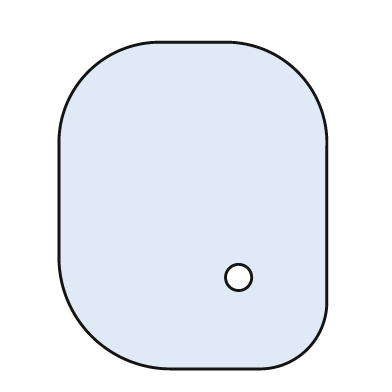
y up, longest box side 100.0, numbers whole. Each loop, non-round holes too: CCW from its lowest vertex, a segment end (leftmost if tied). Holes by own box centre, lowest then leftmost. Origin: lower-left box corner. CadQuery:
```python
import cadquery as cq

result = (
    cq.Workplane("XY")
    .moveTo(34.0, 0.0)
    .lineTo(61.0, 0.0)
    .threePointArc((76.0, 6.0), (82.0, 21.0))
    .lineTo(82.0, 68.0)
    .threePointArc((73.0, 91.0), (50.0, 100.0))
    .lineTo(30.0, 100.0)
    .threePointArc((9.0, 91.0), (0.0, 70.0))
    .lineTo(0.0, 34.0)
    .threePointArc((10.0, 10.0), (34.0, 0.0))
    .close()
    .moveTo(55.0, 28.0)
    .circle(4.0)
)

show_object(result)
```